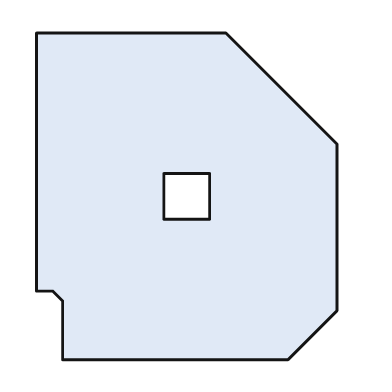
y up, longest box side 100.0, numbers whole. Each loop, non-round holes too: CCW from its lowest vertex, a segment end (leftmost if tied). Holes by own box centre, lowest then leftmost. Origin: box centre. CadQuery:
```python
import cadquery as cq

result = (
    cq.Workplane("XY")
    .moveTo(-38.0, -50.0)
    .lineTo(31.0, -50.0)
    .lineTo(46.0, -35.0)
    .lineTo(46.0, 16.0)
    .lineTo(12.0, 50.0)
    .lineTo(-46.0, 50.0)
    .lineTo(-46.0, -29.0)
    .lineTo(-41.0, -29.0)
    .lineTo(-38.0, -32.0)
    .close()
    .moveTo(-7.0, -7.0)
    .lineTo(7.0, -7.0)
    .lineTo(7.0, 7.0)
    .lineTo(-7.0, 7.0)
    .close()
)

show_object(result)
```